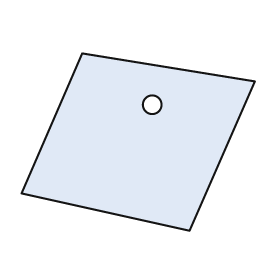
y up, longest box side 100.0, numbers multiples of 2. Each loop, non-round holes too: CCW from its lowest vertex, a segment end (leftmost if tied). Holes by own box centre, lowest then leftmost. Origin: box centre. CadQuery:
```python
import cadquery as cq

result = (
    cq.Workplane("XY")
    .moveTo(22.0, -38.0)
    .lineTo(50.0, 26.0)
    .lineTo(-24.0, 38.0)
    .lineTo(-50.0, -22.0)
    .close()
    .moveTo(6.0, 16.0)
    .circle(4.0)
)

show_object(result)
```